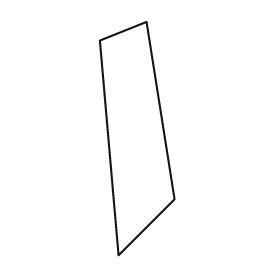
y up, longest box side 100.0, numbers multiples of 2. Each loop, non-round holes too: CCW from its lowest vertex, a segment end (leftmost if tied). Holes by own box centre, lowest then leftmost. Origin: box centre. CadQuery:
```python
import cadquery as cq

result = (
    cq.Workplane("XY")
    .moveTo(-8.0, -50.0)
    .lineTo(16.0, -26.0)
    .lineTo(4.0, 50.0)
    .lineTo(-16.0, 42.0)
    .close()
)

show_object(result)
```